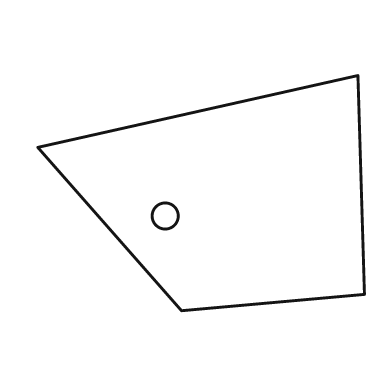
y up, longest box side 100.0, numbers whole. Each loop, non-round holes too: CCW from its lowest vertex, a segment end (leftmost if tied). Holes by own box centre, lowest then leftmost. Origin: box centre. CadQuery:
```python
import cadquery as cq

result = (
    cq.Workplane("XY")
    .moveTo(-6.0, -36.0)
    .lineTo(50.0, -31.0)
    .lineTo(48.0, 36.0)
    .lineTo(-50.0, 14.0)
    .close()
    .moveTo(-11.0, -7.0)
    .circle(4.0)
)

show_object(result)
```